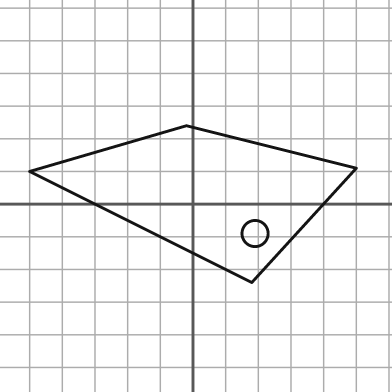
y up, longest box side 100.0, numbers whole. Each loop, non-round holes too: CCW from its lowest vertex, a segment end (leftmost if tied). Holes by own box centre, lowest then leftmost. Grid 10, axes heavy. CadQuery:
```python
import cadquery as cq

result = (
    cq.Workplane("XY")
    .moveTo(18.0, -24.0)
    .lineTo(50.0, 11.0)
    .lineTo(-2.0, 24.0)
    .lineTo(-50.0, 10.0)
    .close()
    .moveTo(19.0, -9.0)
    .circle(4.0)
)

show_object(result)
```